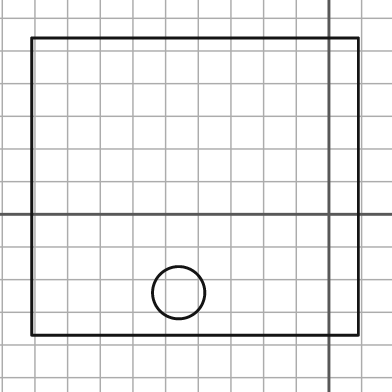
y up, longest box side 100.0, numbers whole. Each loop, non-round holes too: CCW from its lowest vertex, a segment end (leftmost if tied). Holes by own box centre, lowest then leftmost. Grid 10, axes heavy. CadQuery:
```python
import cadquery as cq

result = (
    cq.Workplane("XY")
    .moveTo(-91.0, -37.0)
    .lineTo(9.0, -37.0)
    .lineTo(9.0, 54.0)
    .lineTo(-91.0, 54.0)
    .close()
    .moveTo(-46.0, -24.0)
    .circle(8.0)
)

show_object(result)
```